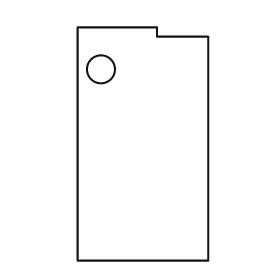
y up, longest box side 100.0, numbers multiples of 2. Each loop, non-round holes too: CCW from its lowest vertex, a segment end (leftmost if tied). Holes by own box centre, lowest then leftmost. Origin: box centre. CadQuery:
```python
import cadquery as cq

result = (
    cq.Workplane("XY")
    .moveTo(-28.0, -50.0)
    .lineTo(28.0, -50.0)
    .lineTo(28.0, 46.0)
    .lineTo(6.0, 46.0)
    .lineTo(6.0, 50.0)
    .lineTo(-28.0, 50.0)
    .close()
    .moveTo(-18.0, 32.0)
    .circle(6.0)
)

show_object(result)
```